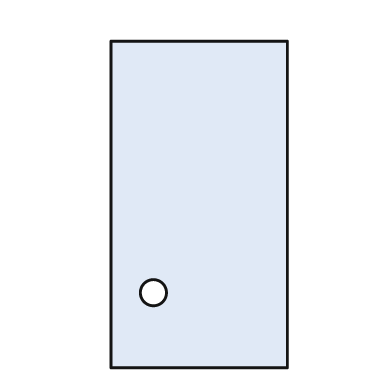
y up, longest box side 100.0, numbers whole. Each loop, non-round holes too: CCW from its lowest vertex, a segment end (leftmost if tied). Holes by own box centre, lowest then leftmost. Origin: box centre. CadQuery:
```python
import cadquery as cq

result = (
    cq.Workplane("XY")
    .moveTo(-27.0, -50.0)
    .lineTo(27.0, -50.0)
    .lineTo(27.0, 50.0)
    .lineTo(-27.0, 50.0)
    .close()
    .moveTo(-14.0, -27.0)
    .circle(4.0)
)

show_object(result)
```